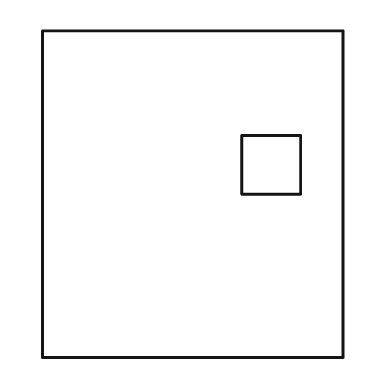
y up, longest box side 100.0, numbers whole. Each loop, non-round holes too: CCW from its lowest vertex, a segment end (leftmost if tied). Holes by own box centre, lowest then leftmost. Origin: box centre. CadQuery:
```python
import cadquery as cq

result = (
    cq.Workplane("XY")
    .moveTo(-46.0, -50.0)
    .lineTo(46.0, -50.0)
    .lineTo(46.0, 50.0)
    .lineTo(-46.0, 50.0)
    .close()
    .moveTo(15.0, 0.0)
    .lineTo(33.0, 0.0)
    .lineTo(33.0, 18.0)
    .lineTo(15.0, 18.0)
    .close()
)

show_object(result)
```